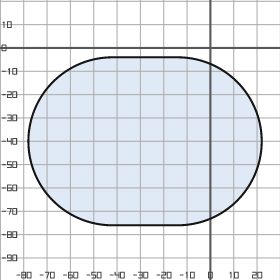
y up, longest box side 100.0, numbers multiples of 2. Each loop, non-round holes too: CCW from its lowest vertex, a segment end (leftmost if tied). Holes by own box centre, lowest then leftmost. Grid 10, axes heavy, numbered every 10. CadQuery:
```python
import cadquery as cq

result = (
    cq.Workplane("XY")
    .moveTo(-42.0, -76.0)
    .lineTo(-14.0, -76.0)
    .threePointArc((22.0, -40.0), (-14.0, -4.0))
    .lineTo(-42.0, -4.0)
    .threePointArc((-78.0, -40.0), (-42.0, -76.0))
    .close()
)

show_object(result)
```